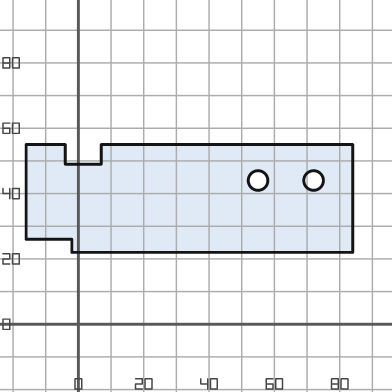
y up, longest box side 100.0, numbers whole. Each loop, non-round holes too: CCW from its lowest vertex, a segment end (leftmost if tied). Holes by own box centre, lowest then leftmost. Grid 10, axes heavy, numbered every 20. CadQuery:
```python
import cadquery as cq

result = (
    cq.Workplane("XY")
    .moveTo(-2.0, 22.0)
    .lineTo(84.0, 22.0)
    .lineTo(84.0, 55.0)
    .lineTo(7.0, 55.0)
    .lineTo(7.0, 49.0)
    .lineTo(-4.0, 49.0)
    .lineTo(-4.0, 55.0)
    .lineTo(-16.0, 55.0)
    .lineTo(-16.0, 26.0)
    .lineTo(-2.0, 26.0)
    .close()
    .moveTo(55.0, 44.0)
    .circle(3.0)
    .moveTo(72.0, 44.0)
    .circle(3.0)
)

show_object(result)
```